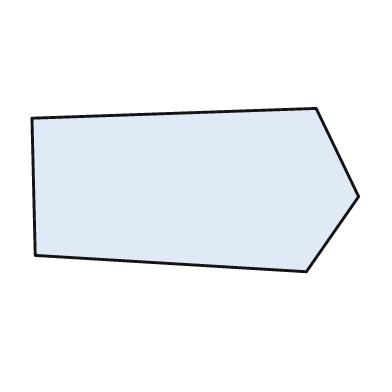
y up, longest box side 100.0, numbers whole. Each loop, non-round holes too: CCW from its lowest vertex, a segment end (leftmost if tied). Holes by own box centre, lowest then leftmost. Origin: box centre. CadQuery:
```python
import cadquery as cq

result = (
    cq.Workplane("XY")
    .moveTo(34.0, -25.0)
    .lineTo(50.0, -2.0)
    .lineTo(37.0, 25.0)
    .lineTo(-50.0, 22.0)
    .lineTo(-49.0, -20.0)
    .close()
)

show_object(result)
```